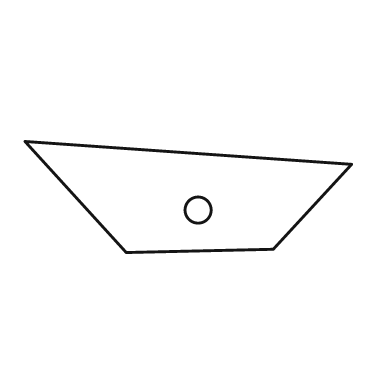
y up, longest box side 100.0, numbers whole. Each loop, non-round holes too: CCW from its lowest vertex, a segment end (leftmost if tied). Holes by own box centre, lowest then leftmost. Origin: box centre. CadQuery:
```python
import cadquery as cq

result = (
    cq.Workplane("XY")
    .moveTo(-19.0, -17.0)
    .lineTo(26.0, -16.0)
    .lineTo(50.0, 10.0)
    .lineTo(-50.0, 17.0)
    .close()
    .moveTo(3.0, -4.0)
    .circle(4.0)
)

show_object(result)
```